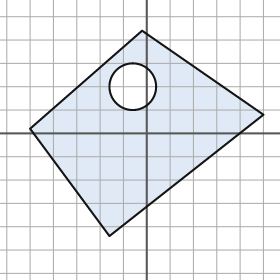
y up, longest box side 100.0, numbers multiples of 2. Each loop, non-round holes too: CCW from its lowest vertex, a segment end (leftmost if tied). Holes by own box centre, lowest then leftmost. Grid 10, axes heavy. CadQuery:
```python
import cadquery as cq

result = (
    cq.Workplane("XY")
    .moveTo(-16.0, -44.0)
    .lineTo(50.0, 8.0)
    .lineTo(-2.0, 44.0)
    .lineTo(-50.0, 2.0)
    .close()
    .moveTo(-6.0, 20.0)
    .circle(10.0)
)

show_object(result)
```